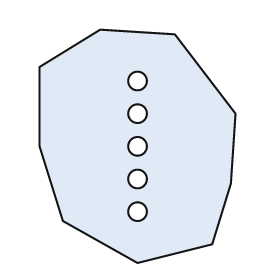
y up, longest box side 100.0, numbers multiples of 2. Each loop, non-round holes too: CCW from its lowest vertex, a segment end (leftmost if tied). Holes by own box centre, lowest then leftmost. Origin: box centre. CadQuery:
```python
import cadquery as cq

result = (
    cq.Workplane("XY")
    .moveTo(0.0, -50.0)
    .lineTo(32.0, -42.0)
    .lineTo(40.0, -16.0)
    .lineTo(42.0, 14.0)
    .lineTo(16.0, 48.0)
    .lineTo(-16.0, 50.0)
    .lineTo(-42.0, 34.0)
    .lineTo(-42.0, 0.0)
    .lineTo(-32.0, -32.0)
    .close()
    .moveTo(0.0, -28.0)
    .circle(4.0)
    .moveTo(0.0, -14.0)
    .circle(4.0)
    .moveTo(0.0, 0.0)
    .circle(4.0)
    .moveTo(0.0, 14.0)
    .circle(4.0)
    .moveTo(0.0, 28.0)
    .circle(4.0)
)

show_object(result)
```